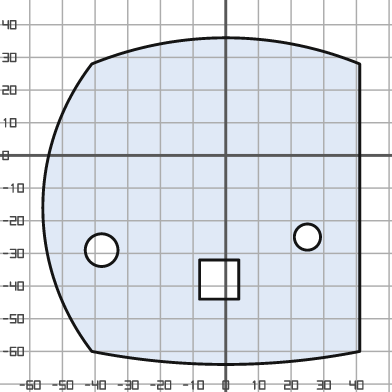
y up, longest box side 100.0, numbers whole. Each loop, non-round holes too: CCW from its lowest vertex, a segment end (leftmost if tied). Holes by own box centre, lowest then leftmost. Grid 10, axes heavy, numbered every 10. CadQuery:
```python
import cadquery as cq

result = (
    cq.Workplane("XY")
    .moveTo(-41.0, -60.0)
    .threePointArc((0.0, -64.0), (41.0, -60.0))
    .lineTo(41.0, 28.0)
    .threePointArc((0.0, 36.0), (-41.0, 28.0))
    .threePointArc((-56.0, -16.0), (-41.0, -60.0))
    .close()
    .moveTo(-8.0, -44.0)
    .lineTo(4.0, -44.0)
    .lineTo(4.0, -32.0)
    .lineTo(-8.0, -32.0)
    .close()
    .moveTo(-38.0, -29.0)
    .circle(5.0)
    .moveTo(25.0, -25.0)
    .circle(4.0)
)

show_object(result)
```